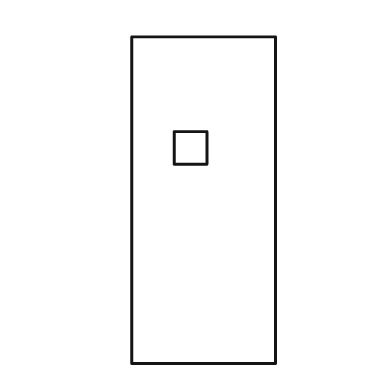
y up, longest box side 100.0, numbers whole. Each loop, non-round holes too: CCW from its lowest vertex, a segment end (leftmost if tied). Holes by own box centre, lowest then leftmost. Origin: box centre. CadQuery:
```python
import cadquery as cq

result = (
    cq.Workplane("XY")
    .moveTo(-22.0, -50.0)
    .lineTo(22.0, -50.0)
    .lineTo(22.0, 50.0)
    .lineTo(-22.0, 50.0)
    .close()
    .moveTo(-9.0, 11.0)
    .lineTo(1.0, 11.0)
    .lineTo(1.0, 21.0)
    .lineTo(-9.0, 21.0)
    .close()
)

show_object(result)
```